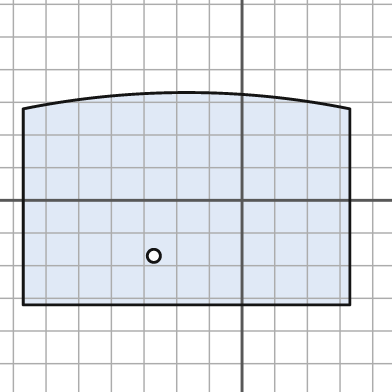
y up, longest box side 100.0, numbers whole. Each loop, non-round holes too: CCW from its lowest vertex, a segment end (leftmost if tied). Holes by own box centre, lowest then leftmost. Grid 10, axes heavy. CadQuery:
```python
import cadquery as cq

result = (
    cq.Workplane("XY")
    .moveTo(-67.0, -32.0)
    .lineTo(33.0, -32.0)
    .lineTo(33.0, 28.0)
    .threePointArc((-17.0, 33.0), (-67.0, 28.0))
    .close()
    .moveTo(-27.0, -17.0)
    .circle(2.0)
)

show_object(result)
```